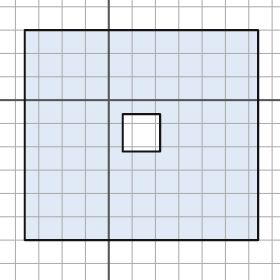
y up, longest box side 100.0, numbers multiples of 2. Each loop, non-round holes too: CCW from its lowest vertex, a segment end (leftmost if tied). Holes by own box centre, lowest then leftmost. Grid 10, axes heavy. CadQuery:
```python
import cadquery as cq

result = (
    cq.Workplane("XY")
    .moveTo(-36.0, -60.0)
    .lineTo(64.0, -60.0)
    .lineTo(64.0, 30.0)
    .lineTo(-36.0, 30.0)
    .close()
    .moveTo(6.0, -22.0)
    .lineTo(22.0, -22.0)
    .lineTo(22.0, -6.0)
    .lineTo(6.0, -6.0)
    .close()
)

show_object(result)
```